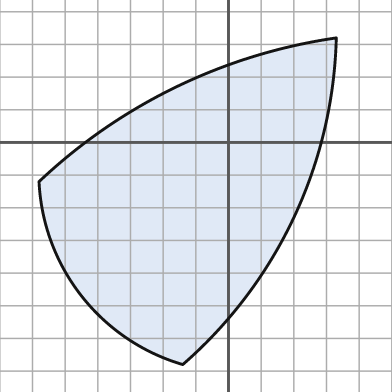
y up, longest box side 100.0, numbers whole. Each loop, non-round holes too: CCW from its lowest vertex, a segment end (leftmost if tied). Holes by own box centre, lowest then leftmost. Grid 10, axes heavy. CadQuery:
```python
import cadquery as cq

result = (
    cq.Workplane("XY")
    .moveTo(-14.0, -68.0)
    .threePointArc((20.0, -23.0), (33.0, 32.0))
    .threePointArc((-16.0, 17.0), (-58.0, -12.0))
    .threePointArc((-45.0, -47.0), (-14.0, -68.0))
    .close()
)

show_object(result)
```